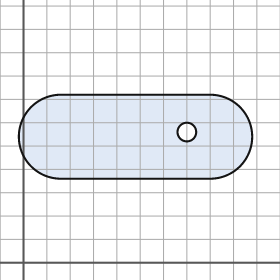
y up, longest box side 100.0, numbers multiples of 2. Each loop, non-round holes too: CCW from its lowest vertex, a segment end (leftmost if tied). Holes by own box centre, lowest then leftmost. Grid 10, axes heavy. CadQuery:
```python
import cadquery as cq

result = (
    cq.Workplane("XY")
    .moveTo(16.0, 36.0)
    .lineTo(80.0, 36.0)
    .threePointArc((98.0, 54.0), (80.0, 72.0))
    .lineTo(16.0, 72.0)
    .threePointArc((-2.0, 54.0), (16.0, 36.0))
    .close()
    .moveTo(70.0, 56.0)
    .circle(4.0)
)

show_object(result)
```